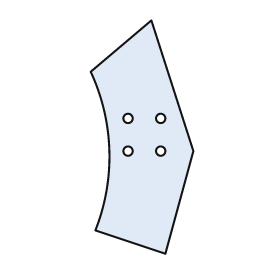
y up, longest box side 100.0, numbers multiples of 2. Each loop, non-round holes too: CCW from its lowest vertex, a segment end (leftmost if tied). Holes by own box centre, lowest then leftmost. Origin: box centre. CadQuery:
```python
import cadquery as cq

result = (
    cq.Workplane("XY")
    .moveTo(10.0, -50.0)
    .lineTo(22.0, -6.0)
    .lineTo(4.0, 50.0)
    .lineTo(-22.0, 28.0)
    .threePointArc((-14.0, -6.0), (-20.0, -40.0))
    .close()
    .moveTo(-6.0, -6.0)
    .circle(2.0)
    .moveTo(8.0, -6.0)
    .circle(2.0)
    .moveTo(-6.0, 8.0)
    .circle(2.0)
    .moveTo(8.0, 8.0)
    .circle(2.0)
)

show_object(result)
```